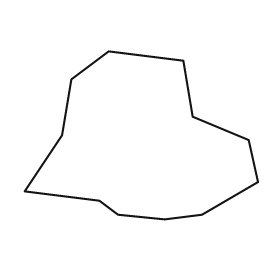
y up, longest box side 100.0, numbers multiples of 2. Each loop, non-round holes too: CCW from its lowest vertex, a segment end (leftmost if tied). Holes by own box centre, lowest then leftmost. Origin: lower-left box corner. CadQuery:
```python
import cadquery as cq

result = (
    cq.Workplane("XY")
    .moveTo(60.0, 0.0)
    .lineTo(76.0, 2.0)
    .lineTo(100.0, 16.0)
    .lineTo(96.0, 34.0)
    .lineTo(72.0, 44.0)
    .lineTo(68.0, 68.0)
    .lineTo(36.0, 72.0)
    .lineTo(20.0, 60.0)
    .lineTo(16.0, 36.0)
    .lineTo(0.0, 12.0)
    .lineTo(32.0, 8.0)
    .lineTo(40.0, 2.0)
    .close()
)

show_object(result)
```